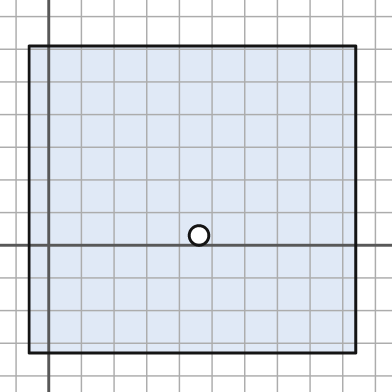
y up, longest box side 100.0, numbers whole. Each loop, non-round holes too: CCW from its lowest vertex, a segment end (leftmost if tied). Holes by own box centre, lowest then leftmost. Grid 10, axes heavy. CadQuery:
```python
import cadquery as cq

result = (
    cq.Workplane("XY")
    .moveTo(-6.0, -33.0)
    .lineTo(94.0, -33.0)
    .lineTo(94.0, 61.0)
    .lineTo(-6.0, 61.0)
    .close()
    .moveTo(46.0, 3.0)
    .circle(3.0)
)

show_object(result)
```